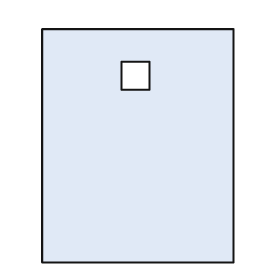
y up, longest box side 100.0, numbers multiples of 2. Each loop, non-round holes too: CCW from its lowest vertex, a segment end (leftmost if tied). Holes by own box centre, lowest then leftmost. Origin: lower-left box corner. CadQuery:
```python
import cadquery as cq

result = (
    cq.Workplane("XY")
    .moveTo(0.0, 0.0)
    .lineTo(82.0, 0.0)
    .lineTo(82.0, 100.0)
    .lineTo(0.0, 100.0)
    .close()
    .moveTo(34.0, 74.0)
    .lineTo(46.0, 74.0)
    .lineTo(46.0, 86.0)
    .lineTo(34.0, 86.0)
    .close()
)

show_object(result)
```